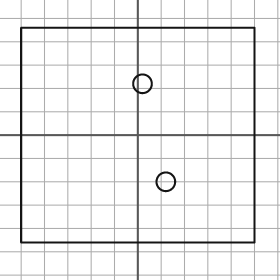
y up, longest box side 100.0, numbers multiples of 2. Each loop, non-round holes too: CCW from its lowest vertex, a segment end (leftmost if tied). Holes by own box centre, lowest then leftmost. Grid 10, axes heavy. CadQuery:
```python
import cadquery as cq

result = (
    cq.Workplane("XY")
    .moveTo(-50.0, -46.0)
    .lineTo(50.0, -46.0)
    .lineTo(50.0, 46.0)
    .lineTo(-50.0, 46.0)
    .close()
    .moveTo(12.0, -20.0)
    .circle(4.0)
    .moveTo(2.0, 22.0)
    .circle(4.0)
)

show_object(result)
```